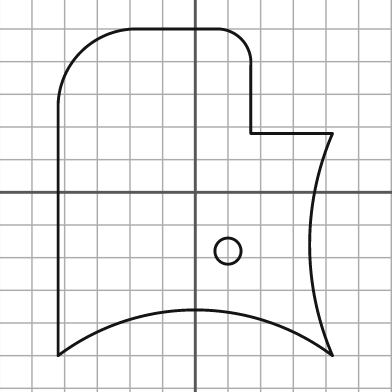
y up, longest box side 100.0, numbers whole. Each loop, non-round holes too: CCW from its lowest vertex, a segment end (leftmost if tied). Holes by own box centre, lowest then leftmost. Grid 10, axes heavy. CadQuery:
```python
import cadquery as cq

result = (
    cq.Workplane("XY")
    .moveTo(-42.0, -50.0)
    .threePointArc((0.0, -36.0), (42.0, -50.0))
    .threePointArc((35.0, -16.0), (42.0, 18.0))
    .lineTo(17.0, 18.0)
    .lineTo(17.0, 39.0)
    .threePointArc((14.0, 47.0), (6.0, 50.0))
    .lineTo(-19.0, 50.0)
    .threePointArc((-35.0, 43.0), (-42.0, 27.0))
    .close()
    .moveTo(10.0, -18.0)
    .circle(4.0)
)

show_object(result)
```